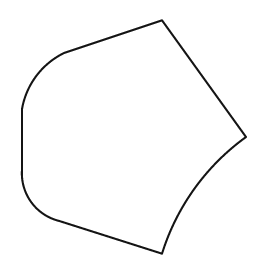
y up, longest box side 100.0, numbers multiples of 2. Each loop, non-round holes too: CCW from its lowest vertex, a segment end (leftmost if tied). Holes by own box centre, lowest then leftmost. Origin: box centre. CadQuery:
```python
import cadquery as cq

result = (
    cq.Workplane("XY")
    .moveTo(12.0, -50.0)
    .threePointArc((26.0, -22.0), (48.0, 0.0))
    .lineTo(12.0, 50.0)
    .lineTo(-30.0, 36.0)
    .threePointArc((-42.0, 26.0), (-48.0, 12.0))
    .lineTo(-48.0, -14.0)
    .threePointArc((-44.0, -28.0), (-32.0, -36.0))
    .close()
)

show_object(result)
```